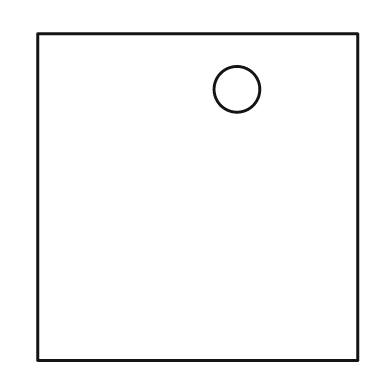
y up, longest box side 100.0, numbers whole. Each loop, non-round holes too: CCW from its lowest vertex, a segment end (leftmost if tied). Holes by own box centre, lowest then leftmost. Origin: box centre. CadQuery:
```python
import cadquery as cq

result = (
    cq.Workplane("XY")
    .moveTo(-49.0, -50.0)
    .lineTo(49.0, -50.0)
    .lineTo(49.0, 50.0)
    .lineTo(-49.0, 50.0)
    .close()
    .moveTo(12.0, 33.0)
    .circle(7.0)
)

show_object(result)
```